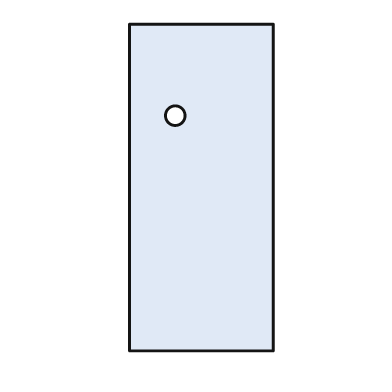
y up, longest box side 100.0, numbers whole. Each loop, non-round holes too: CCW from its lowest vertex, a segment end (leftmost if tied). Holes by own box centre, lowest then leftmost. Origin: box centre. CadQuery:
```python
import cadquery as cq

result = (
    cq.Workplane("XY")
    .moveTo(-22.0, -50.0)
    .lineTo(22.0, -50.0)
    .lineTo(22.0, 50.0)
    .lineTo(-22.0, 50.0)
    .close()
    .moveTo(-8.0, 22.0)
    .circle(3.0)
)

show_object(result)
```